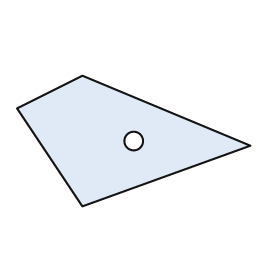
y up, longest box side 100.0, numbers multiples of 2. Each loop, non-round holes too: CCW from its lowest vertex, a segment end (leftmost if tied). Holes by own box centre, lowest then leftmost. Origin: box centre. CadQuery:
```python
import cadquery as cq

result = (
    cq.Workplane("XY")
    .moveTo(-22.0, -28.0)
    .lineTo(50.0, -2.0)
    .lineTo(-22.0, 28.0)
    .lineTo(-50.0, 14.0)
    .close()
    .moveTo(0.0, 0.0)
    .circle(4.0)
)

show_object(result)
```